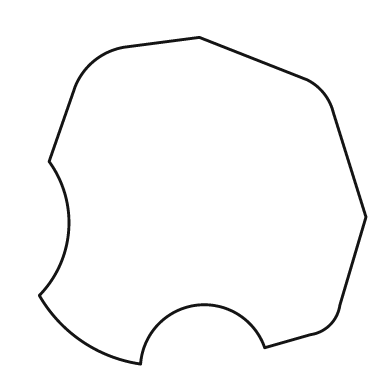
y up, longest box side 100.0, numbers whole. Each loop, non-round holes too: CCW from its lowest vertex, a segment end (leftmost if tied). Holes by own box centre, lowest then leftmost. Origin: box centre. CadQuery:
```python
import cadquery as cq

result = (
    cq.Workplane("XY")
    .moveTo(-19.0, -50.0)
    .threePointArc((-2.0, -32.0), (19.0, -45.0))
    .lineTo(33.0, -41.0)
    .threePointArc((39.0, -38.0), (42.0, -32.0))
    .lineTo(50.0, -5.0)
    .lineTo(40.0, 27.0)
    .threePointArc((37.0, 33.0), (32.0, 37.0))
    .lineTo(-1.0, 50.0)
    .lineTo(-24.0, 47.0)
    .threePointArc((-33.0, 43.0), (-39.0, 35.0))
    .lineTo(-47.0, 12.0)
    .threePointArc((-41.0, -9.0), (-50.0, -29.0))
    .threePointArc((-37.0, -43.0), (-19.0, -50.0))
    .close()
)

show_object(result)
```